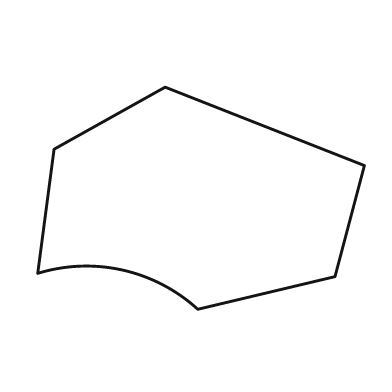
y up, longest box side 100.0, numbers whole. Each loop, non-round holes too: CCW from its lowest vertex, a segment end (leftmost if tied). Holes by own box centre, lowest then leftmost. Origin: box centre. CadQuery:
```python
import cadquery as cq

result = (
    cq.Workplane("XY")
    .moveTo(-1.0, -34.0)
    .lineTo(41.0, -24.0)
    .lineTo(50.0, 10.0)
    .lineTo(-11.0, 34.0)
    .lineTo(-45.0, 15.0)
    .lineTo(-50.0, -23.0)
    .threePointArc((-24.0, -22.0), (-1.0, -34.0))
    .close()
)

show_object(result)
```